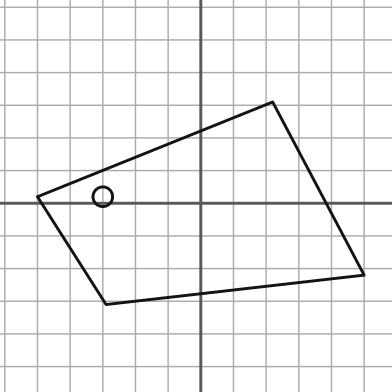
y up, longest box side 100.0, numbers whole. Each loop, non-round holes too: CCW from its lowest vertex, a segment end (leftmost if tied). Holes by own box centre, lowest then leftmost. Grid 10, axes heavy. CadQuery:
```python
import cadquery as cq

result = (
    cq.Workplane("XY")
    .moveTo(-29.0, -31.0)
    .lineTo(50.0, -22.0)
    .lineTo(22.0, 31.0)
    .lineTo(-50.0, 2.0)
    .close()
    .moveTo(-30.0, 2.0)
    .circle(3.0)
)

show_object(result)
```